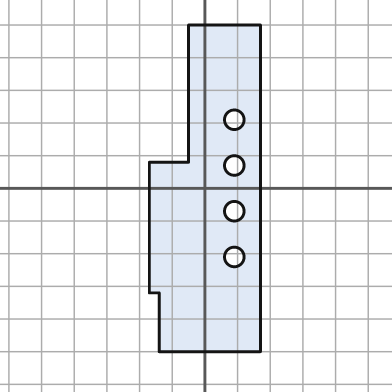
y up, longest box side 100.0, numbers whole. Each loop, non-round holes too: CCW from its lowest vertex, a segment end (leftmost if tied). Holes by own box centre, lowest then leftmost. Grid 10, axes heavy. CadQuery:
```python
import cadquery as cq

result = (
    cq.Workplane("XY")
    .moveTo(-14.0, -50.0)
    .lineTo(17.0, -50.0)
    .lineTo(17.0, 50.0)
    .lineTo(-5.0, 50.0)
    .lineTo(-5.0, 8.0)
    .lineTo(-17.0, 8.0)
    .lineTo(-17.0, -32.0)
    .lineTo(-14.0, -32.0)
    .close()
    .moveTo(9.0, -21.0)
    .circle(3.0)
    .moveTo(9.0, -7.0)
    .circle(3.0)
    .moveTo(9.0, 7.0)
    .circle(3.0)
    .moveTo(9.0, 21.0)
    .circle(3.0)
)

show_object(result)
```